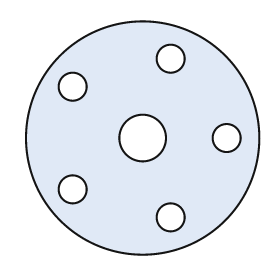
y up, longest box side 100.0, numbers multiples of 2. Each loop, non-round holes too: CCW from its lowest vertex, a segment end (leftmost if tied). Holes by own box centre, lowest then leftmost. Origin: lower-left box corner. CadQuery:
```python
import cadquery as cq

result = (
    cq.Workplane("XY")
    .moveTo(50.0, 50.0)
    .circle(50.0)
    .moveTo(62.0, 16.0)
    .circle(6.0)
    .moveTo(20.0, 28.0)
    .circle(6.0)
    .moveTo(50.0, 50.0)
    .circle(10.0)
    .moveTo(86.0, 50.0)
    .circle(6.0)
    .moveTo(20.0, 72.0)
    .circle(6.0)
    .moveTo(62.0, 84.0)
    .circle(6.0)
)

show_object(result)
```